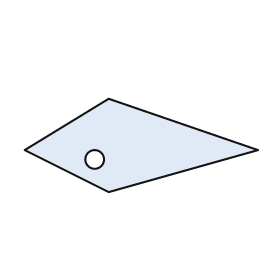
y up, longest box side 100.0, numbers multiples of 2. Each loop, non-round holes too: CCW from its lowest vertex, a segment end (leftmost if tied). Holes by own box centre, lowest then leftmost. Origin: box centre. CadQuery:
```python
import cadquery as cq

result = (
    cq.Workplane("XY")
    .moveTo(-14.0, -20.0)
    .lineTo(50.0, -2.0)
    .lineTo(-14.0, 20.0)
    .lineTo(-50.0, -2.0)
    .close()
    .moveTo(-20.0, -6.0)
    .circle(4.0)
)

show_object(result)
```